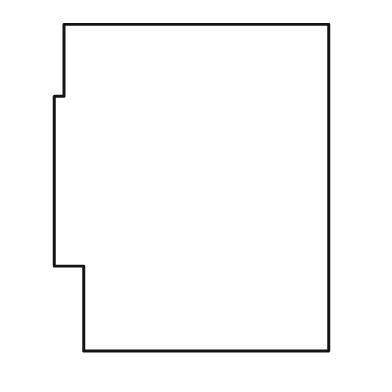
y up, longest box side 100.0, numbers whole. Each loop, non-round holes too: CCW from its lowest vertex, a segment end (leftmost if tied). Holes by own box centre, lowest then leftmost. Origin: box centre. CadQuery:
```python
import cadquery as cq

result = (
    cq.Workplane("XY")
    .moveTo(-33.0, -50.0)
    .lineTo(42.0, -50.0)
    .lineTo(42.0, 50.0)
    .lineTo(-39.0, 50.0)
    .lineTo(-39.0, 28.0)
    .lineTo(-42.0, 28.0)
    .lineTo(-42.0, -24.0)
    .lineTo(-33.0, -24.0)
    .close()
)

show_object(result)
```